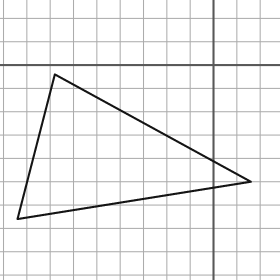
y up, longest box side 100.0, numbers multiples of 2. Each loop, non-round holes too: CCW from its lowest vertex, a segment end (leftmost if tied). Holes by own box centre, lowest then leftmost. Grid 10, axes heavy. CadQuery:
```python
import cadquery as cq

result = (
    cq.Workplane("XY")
    .moveTo(-84.0, -66.0)
    .lineTo(16.0, -50.0)
    .lineTo(-68.0, -4.0)
    .close()
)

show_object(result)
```